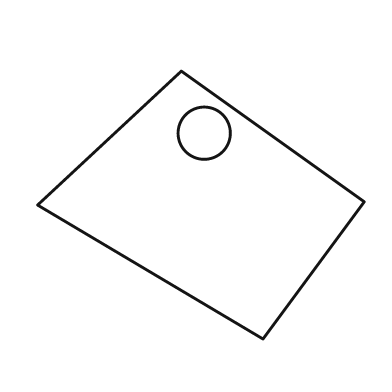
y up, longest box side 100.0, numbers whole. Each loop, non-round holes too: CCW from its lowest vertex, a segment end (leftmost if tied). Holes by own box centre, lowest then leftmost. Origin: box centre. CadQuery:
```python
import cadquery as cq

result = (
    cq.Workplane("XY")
    .moveTo(19.0, -41.0)
    .lineTo(50.0, 1.0)
    .lineTo(-6.0, 41.0)
    .lineTo(-50.0, 0.0)
    .close()
    .moveTo(1.0, 22.0)
    .circle(8.0)
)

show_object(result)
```